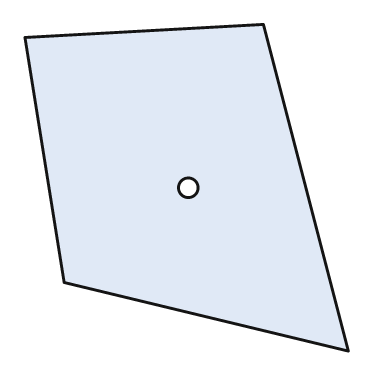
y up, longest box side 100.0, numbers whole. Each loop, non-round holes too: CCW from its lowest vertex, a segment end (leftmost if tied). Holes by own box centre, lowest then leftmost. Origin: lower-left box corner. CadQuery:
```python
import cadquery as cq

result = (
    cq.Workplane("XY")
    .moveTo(99.0, 0.0)
    .lineTo(73.0, 100.0)
    .lineTo(0.0, 96.0)
    .lineTo(12.0, 21.0)
    .close()
    .moveTo(50.0, 50.0)
    .circle(3.0)
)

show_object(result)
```